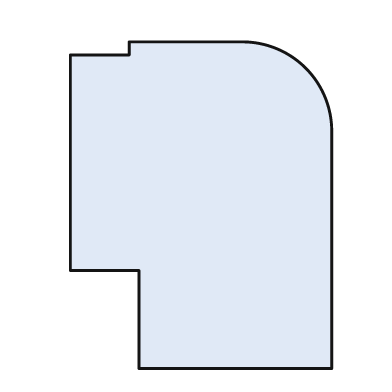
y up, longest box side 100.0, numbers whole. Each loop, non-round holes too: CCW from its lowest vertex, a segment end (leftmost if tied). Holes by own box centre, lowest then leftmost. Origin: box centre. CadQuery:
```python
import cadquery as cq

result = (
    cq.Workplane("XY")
    .moveTo(-19.0, -50.0)
    .lineTo(40.0, -50.0)
    .lineTo(40.0, 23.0)
    .threePointArc((32.0, 42.0), (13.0, 50.0))
    .lineTo(-22.0, 50.0)
    .lineTo(-22.0, 46.0)
    .lineTo(-40.0, 46.0)
    .lineTo(-40.0, -20.0)
    .lineTo(-19.0, -20.0)
    .close()
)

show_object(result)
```